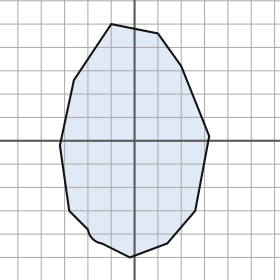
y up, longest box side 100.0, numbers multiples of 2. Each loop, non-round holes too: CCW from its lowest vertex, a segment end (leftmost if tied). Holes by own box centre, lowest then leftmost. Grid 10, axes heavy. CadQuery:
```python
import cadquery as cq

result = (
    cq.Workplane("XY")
    .moveTo(-2.0, -50.0)
    .lineTo(14.0, -44.0)
    .lineTo(26.0, -30.0)
    .lineTo(32.0, 2.0)
    .lineTo(20.0, 32.0)
    .lineTo(10.0, 46.0)
    .lineTo(-10.0, 50.0)
    .lineTo(-26.0, 26.0)
    .lineTo(-32.0, -2.0)
    .lineTo(-28.0, -30.0)
    .lineTo(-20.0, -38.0)
    .threePointArc((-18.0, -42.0), (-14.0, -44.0))
    .close()
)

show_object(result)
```